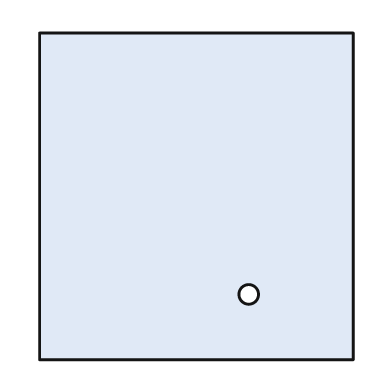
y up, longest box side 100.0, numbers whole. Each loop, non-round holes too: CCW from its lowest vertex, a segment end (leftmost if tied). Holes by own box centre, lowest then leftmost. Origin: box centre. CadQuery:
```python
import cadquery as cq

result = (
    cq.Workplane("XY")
    .moveTo(-48.0, -50.0)
    .lineTo(48.0, -50.0)
    .lineTo(48.0, 50.0)
    .lineTo(-48.0, 50.0)
    .close()
    .moveTo(16.0, -30.0)
    .circle(3.0)
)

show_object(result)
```